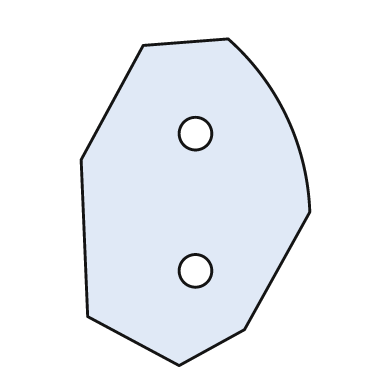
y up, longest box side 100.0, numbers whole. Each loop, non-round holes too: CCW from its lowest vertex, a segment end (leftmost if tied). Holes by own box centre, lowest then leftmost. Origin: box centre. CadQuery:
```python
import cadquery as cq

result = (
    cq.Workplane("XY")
    .moveTo(-5.0, -50.0)
    .lineTo(15.0, -39.0)
    .lineTo(35.0, -3.0)
    .threePointArc((28.0, 26.0), (10.0, 50.0))
    .lineTo(-16.0, 48.0)
    .lineTo(-35.0, 13.0)
    .lineTo(-33.0, -35.0)
    .close()
    .moveTo(0.0, -21.0)
    .circle(5.0)
    .moveTo(0.0, 21.0)
    .circle(5.0)
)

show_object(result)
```